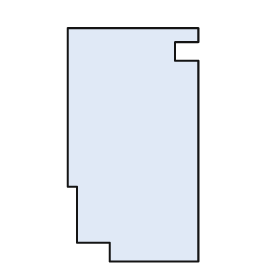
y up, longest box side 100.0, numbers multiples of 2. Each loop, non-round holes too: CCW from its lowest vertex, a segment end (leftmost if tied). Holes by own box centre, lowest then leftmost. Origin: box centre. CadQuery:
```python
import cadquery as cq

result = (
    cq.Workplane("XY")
    .moveTo(-10.0, -50.0)
    .lineTo(28.0, -50.0)
    .lineTo(28.0, 36.0)
    .lineTo(18.0, 36.0)
    .lineTo(18.0, 44.0)
    .lineTo(28.0, 44.0)
    .lineTo(28.0, 50.0)
    .lineTo(-28.0, 50.0)
    .lineTo(-28.0, -18.0)
    .lineTo(-24.0, -18.0)
    .lineTo(-24.0, -42.0)
    .lineTo(-10.0, -42.0)
    .close()
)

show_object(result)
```